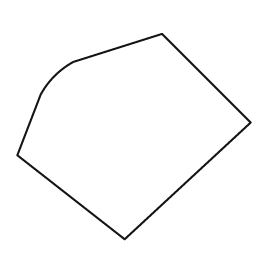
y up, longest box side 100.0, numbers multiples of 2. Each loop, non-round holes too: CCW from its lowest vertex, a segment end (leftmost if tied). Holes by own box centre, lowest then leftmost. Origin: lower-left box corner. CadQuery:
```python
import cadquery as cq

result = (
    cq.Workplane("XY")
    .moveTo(46.0, 0.0)
    .lineTo(100.0, 50.0)
    .lineTo(62.0, 88.0)
    .lineTo(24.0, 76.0)
    .threePointArc((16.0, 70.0), (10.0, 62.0))
    .lineTo(0.0, 36.0)
    .close()
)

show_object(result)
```